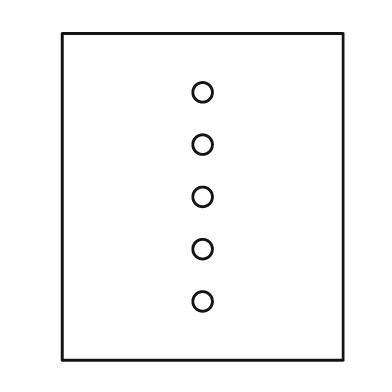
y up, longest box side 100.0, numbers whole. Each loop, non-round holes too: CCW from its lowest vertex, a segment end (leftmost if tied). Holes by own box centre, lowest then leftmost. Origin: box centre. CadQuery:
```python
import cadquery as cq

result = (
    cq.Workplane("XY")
    .moveTo(-43.0, -50.0)
    .lineTo(43.0, -50.0)
    .lineTo(43.0, 50.0)
    .lineTo(-43.0, 50.0)
    .close()
    .moveTo(0.0, -32.0)
    .circle(3.0)
    .moveTo(0.0, -16.0)
    .circle(3.0)
    .moveTo(0.0, 0.0)
    .circle(3.0)
    .moveTo(0.0, 16.0)
    .circle(3.0)
    .moveTo(0.0, 32.0)
    .circle(3.0)
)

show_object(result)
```